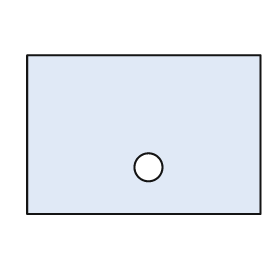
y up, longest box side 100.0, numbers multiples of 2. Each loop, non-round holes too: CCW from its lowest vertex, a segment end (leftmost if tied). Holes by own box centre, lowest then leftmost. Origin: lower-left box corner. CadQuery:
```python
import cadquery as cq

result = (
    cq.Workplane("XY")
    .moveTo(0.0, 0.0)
    .lineTo(100.0, 0.0)
    .lineTo(100.0, 68.0)
    .lineTo(0.0, 68.0)
    .close()
    .moveTo(52.0, 20.0)
    .circle(6.0)
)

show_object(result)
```